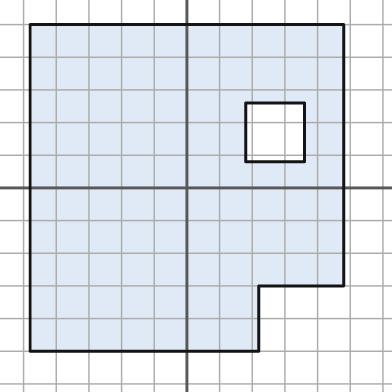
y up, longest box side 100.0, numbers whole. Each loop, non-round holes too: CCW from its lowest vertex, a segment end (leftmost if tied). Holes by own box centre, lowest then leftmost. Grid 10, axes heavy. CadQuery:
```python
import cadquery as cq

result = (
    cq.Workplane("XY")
    .moveTo(-48.0, -50.0)
    .lineTo(22.0, -50.0)
    .lineTo(22.0, -30.0)
    .lineTo(48.0, -30.0)
    .lineTo(48.0, 50.0)
    .lineTo(-48.0, 50.0)
    .close()
    .moveTo(18.0, 8.0)
    .lineTo(36.0, 8.0)
    .lineTo(36.0, 26.0)
    .lineTo(18.0, 26.0)
    .close()
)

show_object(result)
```